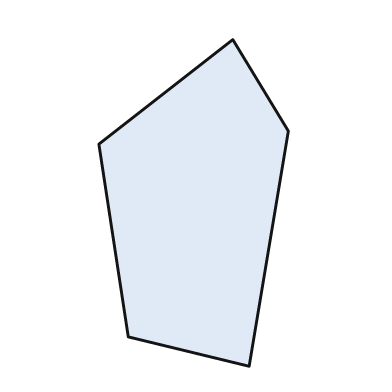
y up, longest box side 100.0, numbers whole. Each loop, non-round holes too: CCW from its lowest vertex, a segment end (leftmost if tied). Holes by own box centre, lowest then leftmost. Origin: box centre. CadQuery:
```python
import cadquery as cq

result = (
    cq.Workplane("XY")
    .moveTo(17.0, -50.0)
    .lineTo(29.0, 22.0)
    .lineTo(12.0, 50.0)
    .lineTo(-29.0, 18.0)
    .lineTo(-20.0, -41.0)
    .close()
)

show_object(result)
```